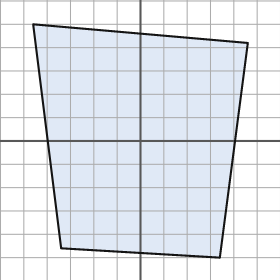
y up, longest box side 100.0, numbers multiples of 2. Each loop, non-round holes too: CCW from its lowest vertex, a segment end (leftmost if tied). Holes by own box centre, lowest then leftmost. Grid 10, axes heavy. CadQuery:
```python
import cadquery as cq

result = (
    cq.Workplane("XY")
    .moveTo(34.0, -50.0)
    .lineTo(46.0, 42.0)
    .lineTo(-46.0, 50.0)
    .lineTo(-34.0, -46.0)
    .close()
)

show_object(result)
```